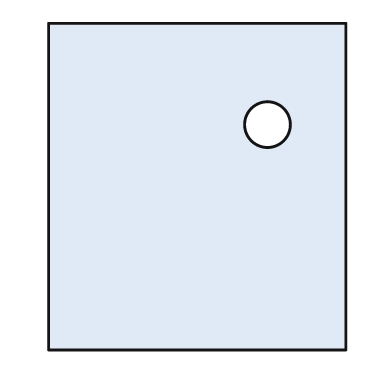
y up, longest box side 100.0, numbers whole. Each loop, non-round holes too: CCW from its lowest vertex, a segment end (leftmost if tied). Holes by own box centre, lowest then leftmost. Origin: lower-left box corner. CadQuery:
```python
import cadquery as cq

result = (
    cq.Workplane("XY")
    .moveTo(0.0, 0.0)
    .lineTo(91.0, 0.0)
    .lineTo(91.0, 100.0)
    .lineTo(0.0, 100.0)
    .close()
    .moveTo(67.0, 69.0)
    .circle(7.0)
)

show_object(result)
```